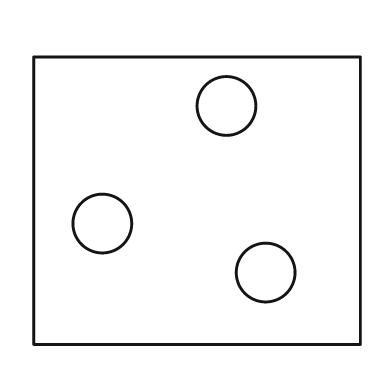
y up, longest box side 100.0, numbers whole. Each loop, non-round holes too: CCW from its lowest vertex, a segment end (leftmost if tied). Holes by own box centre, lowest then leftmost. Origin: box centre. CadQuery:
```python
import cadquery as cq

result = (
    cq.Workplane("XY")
    .moveTo(-50.0, -44.0)
    .lineTo(50.0, -44.0)
    .lineTo(50.0, 44.0)
    .lineTo(-50.0, 44.0)
    .close()
    .moveTo(21.0, -22.0)
    .circle(9.0)
    .moveTo(-29.0, -7.0)
    .circle(9.0)
    .moveTo(9.0, 29.0)
    .circle(9.0)
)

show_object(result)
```